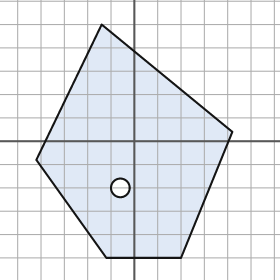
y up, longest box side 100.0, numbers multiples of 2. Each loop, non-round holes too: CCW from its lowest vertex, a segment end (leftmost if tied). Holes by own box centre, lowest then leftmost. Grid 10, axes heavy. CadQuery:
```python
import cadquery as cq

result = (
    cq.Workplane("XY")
    .moveTo(-12.0, -50.0)
    .lineTo(20.0, -50.0)
    .lineTo(42.0, 4.0)
    .lineTo(-14.0, 50.0)
    .lineTo(-42.0, -8.0)
    .close()
    .moveTo(-6.0, -20.0)
    .circle(4.0)
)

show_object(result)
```